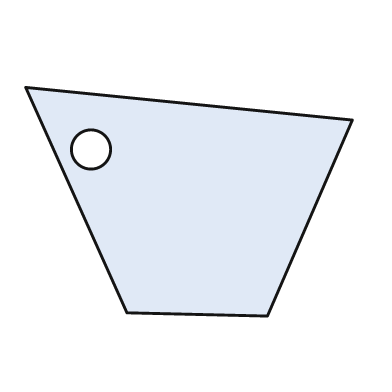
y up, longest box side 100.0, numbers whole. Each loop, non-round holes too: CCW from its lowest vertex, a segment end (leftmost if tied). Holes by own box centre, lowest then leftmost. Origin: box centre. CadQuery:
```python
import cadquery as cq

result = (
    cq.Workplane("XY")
    .moveTo(24.0, -35.0)
    .lineTo(50.0, 25.0)
    .lineTo(-50.0, 35.0)
    .lineTo(-19.0, -34.0)
    .close()
    .moveTo(-30.0, 16.0)
    .circle(6.0)
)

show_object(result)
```